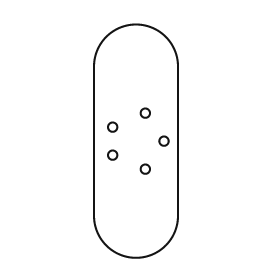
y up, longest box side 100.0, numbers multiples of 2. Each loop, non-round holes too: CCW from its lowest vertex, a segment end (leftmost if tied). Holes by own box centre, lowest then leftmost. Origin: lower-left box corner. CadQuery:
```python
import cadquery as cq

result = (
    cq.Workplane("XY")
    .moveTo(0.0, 18.0)
    .threePointArc((18.0, 0.0), (36.0, 18.0))
    .lineTo(36.0, 82.0)
    .threePointArc((18.0, 100.0), (0.0, 82.0))
    .close()
    .moveTo(22.0, 38.0)
    .circle(2.0)
    .moveTo(8.0, 44.0)
    .circle(2.0)
    .moveTo(30.0, 50.0)
    .circle(2.0)
    .moveTo(8.0, 56.0)
    .circle(2.0)
    .moveTo(22.0, 62.0)
    .circle(2.0)
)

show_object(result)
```